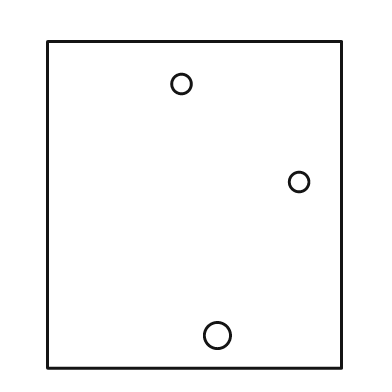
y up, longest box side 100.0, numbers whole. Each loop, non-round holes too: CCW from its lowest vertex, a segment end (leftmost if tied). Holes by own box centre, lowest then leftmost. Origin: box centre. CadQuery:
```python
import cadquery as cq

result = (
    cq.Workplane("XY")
    .moveTo(-45.0, -50.0)
    .lineTo(45.0, -50.0)
    .lineTo(45.0, 50.0)
    .lineTo(-45.0, 50.0)
    .close()
    .moveTo(7.0, -40.0)
    .circle(4.0)
    .moveTo(32.0, 7.0)
    .circle(3.0)
    .moveTo(-4.0, 37.0)
    .circle(3.0)
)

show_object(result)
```